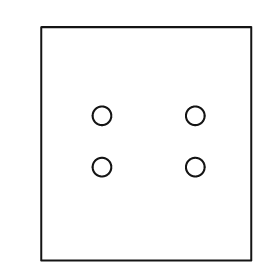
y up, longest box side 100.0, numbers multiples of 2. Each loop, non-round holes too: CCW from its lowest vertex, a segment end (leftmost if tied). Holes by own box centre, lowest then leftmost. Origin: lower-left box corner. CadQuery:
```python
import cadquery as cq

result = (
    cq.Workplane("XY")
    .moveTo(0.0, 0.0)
    .lineTo(90.0, 0.0)
    .lineTo(90.0, 100.0)
    .lineTo(0.0, 100.0)
    .close()
    .moveTo(26.0, 40.0)
    .circle(4.0)
    .moveTo(66.0, 40.0)
    .circle(4.0)
    .moveTo(26.0, 62.0)
    .circle(4.0)
    .moveTo(66.0, 62.0)
    .circle(4.0)
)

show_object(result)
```